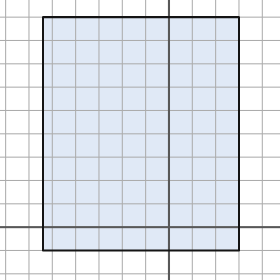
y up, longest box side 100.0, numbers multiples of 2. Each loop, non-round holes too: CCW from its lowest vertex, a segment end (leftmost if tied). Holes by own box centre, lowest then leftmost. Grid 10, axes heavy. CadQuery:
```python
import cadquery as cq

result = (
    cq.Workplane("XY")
    .moveTo(-54.0, -10.0)
    .lineTo(30.0, -10.0)
    .lineTo(30.0, 90.0)
    .lineTo(-54.0, 90.0)
    .close()
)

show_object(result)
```